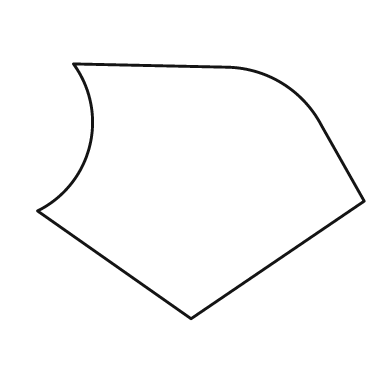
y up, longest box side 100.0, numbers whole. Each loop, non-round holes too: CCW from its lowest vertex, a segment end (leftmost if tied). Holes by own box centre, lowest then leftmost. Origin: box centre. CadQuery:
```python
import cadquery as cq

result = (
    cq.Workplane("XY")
    .moveTo(-3.0, -39.0)
    .lineTo(50.0, -3.0)
    .lineTo(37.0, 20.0)
    .threePointArc((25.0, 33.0), (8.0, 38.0))
    .lineTo(-39.0, 39.0)
    .threePointArc((-34.0, 14.0), (-50.0, -6.0))
    .close()
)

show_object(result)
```